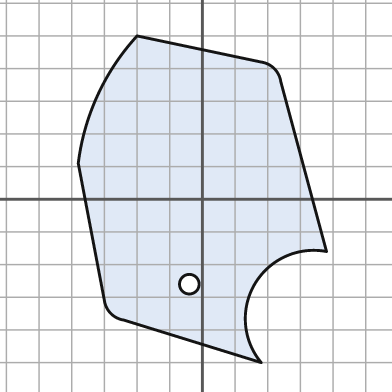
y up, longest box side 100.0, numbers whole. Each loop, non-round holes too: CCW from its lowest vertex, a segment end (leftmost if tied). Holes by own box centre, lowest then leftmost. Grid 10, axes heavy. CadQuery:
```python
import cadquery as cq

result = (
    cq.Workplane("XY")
    .moveTo(18.0, -50.0)
    .threePointArc((16.0, -26.0), (38.0, -16.0))
    .lineTo(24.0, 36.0)
    .threePointArc((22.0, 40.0), (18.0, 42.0))
    .lineTo(-20.0, 50.0)
    .threePointArc((-32.0, 32.0), (-38.0, 11.0))
    .lineTo(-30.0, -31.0)
    .threePointArc((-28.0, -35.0), (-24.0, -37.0))
    .close()
    .moveTo(-4.0, -26.0)
    .circle(3.0)
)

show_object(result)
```